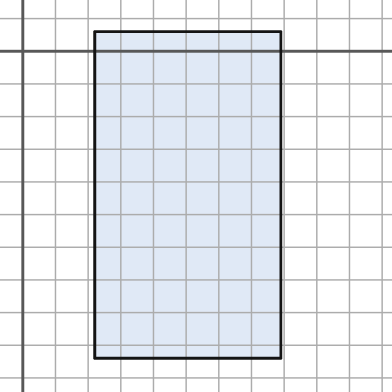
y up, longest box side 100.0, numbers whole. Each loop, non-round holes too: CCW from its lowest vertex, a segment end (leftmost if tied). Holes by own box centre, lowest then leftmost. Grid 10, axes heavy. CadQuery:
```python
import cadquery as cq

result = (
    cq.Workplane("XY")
    .moveTo(22.0, -94.0)
    .lineTo(79.0, -94.0)
    .lineTo(79.0, 6.0)
    .lineTo(22.0, 6.0)
    .close()
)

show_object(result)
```